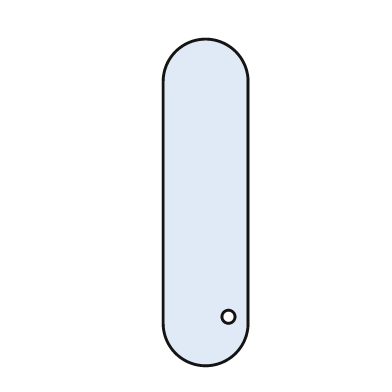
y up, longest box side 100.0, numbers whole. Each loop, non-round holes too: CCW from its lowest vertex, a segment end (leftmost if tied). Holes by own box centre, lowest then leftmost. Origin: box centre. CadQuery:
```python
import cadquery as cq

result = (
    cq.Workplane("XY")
    .moveTo(-13.0, -37.0)
    .threePointArc((0.0, -50.0), (13.0, -37.0))
    .lineTo(13.0, 37.0)
    .threePointArc((0.0, 50.0), (-13.0, 37.0))
    .close()
    .moveTo(7.0, -35.0)
    .circle(2.0)
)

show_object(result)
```